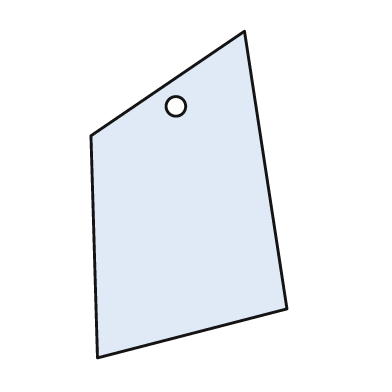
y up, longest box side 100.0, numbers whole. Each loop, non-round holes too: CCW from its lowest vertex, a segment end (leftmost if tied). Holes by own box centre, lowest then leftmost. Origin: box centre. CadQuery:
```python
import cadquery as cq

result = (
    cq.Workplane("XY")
    .moveTo(-28.0, -50.0)
    .lineTo(30.0, -35.0)
    .lineTo(17.0, 50.0)
    .lineTo(-30.0, 18.0)
    .close()
    .moveTo(-4.0, 27.0)
    .circle(3.0)
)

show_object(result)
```